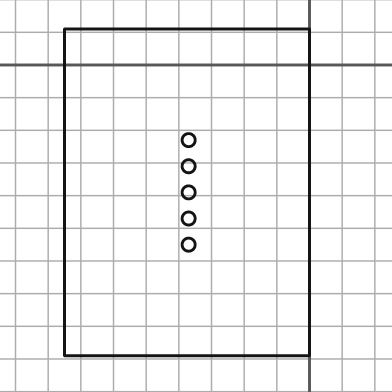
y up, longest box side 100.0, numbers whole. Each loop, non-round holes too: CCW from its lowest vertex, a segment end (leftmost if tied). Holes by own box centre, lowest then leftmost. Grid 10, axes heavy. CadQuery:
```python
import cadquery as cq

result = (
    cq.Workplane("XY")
    .moveTo(-75.0, -89.0)
    .lineTo(0.0, -89.0)
    .lineTo(0.0, 11.0)
    .lineTo(-75.0, 11.0)
    .close()
    .moveTo(-37.0, -55.0)
    .circle(2.0)
    .moveTo(-37.0, -47.0)
    .circle(2.0)
    .moveTo(-37.0, -39.0)
    .circle(2.0)
    .moveTo(-37.0, -31.0)
    .circle(2.0)
    .moveTo(-37.0, -23.0)
    .circle(2.0)
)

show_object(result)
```